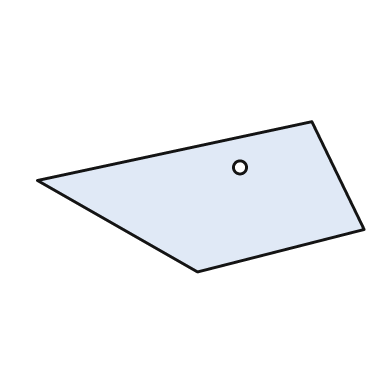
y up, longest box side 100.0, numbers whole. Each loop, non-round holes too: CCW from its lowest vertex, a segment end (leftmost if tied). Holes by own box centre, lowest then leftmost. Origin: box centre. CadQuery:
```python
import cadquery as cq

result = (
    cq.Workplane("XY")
    .moveTo(-1.0, -23.0)
    .lineTo(50.0, -10.0)
    .lineTo(34.0, 23.0)
    .lineTo(-50.0, 5.0)
    .close()
    .moveTo(12.0, 9.0)
    .circle(2.0)
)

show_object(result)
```